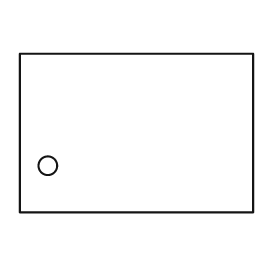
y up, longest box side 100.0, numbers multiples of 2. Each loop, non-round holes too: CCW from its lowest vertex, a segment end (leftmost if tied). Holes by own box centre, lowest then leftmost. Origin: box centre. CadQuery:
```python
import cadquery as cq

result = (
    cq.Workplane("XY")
    .moveTo(-50.0, -34.0)
    .lineTo(50.0, -34.0)
    .lineTo(50.0, 34.0)
    .lineTo(-50.0, 34.0)
    .close()
    .moveTo(-38.0, -14.0)
    .circle(4.0)
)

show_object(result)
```